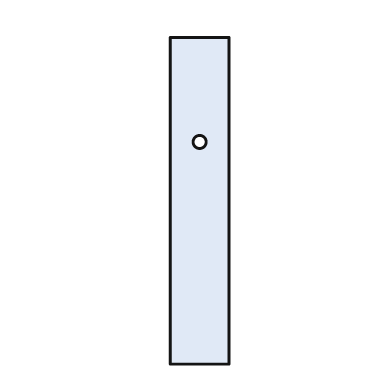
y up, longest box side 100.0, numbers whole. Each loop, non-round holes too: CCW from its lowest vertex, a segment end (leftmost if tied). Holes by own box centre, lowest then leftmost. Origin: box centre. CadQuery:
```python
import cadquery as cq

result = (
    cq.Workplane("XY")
    .moveTo(-9.0, -50.0)
    .lineTo(9.0, -50.0)
    .lineTo(9.0, 50.0)
    .lineTo(-9.0, 50.0)
    .close()
    .moveTo(0.0, 18.0)
    .circle(2.0)
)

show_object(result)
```